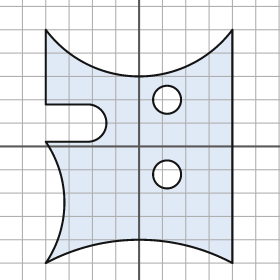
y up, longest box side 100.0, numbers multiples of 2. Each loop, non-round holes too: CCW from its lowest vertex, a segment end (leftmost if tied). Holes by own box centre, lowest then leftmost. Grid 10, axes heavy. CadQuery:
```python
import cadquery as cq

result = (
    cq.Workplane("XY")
    .moveTo(-40.0, -50.0)
    .threePointArc((0.0, -40.0), (40.0, -50.0))
    .lineTo(40.0, 50.0)
    .threePointArc((0.0, 30.0), (-40.0, 50.0))
    .lineTo(-40.0, 18.0)
    .lineTo(-22.0, 18.0)
    .threePointArc((-14.0, 10.0), (-22.0, 2.0))
    .lineTo(-40.0, 2.0)
    .threePointArc((-32.0, -24.0), (-40.0, -50.0))
    .close()
    .moveTo(12.0, -12.0)
    .circle(6.0)
    .moveTo(12.0, 20.0)
    .circle(6.0)
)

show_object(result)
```